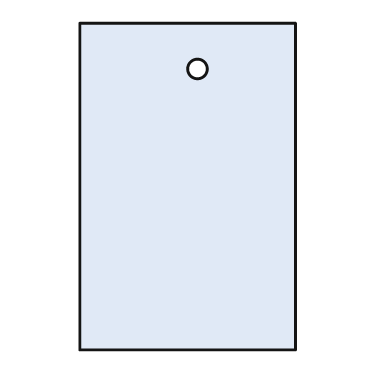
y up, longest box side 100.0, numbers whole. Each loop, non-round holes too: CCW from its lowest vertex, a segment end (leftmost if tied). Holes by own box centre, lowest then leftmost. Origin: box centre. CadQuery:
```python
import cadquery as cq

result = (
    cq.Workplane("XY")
    .moveTo(-33.0, -50.0)
    .lineTo(33.0, -50.0)
    .lineTo(33.0, 50.0)
    .lineTo(-33.0, 50.0)
    .close()
    .moveTo(3.0, 36.0)
    .circle(3.0)
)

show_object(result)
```